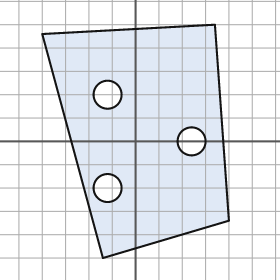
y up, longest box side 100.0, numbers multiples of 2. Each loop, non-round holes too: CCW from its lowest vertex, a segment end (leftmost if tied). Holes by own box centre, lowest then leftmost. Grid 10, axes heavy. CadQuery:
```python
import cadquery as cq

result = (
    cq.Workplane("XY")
    .moveTo(-14.0, -50.0)
    .lineTo(40.0, -34.0)
    .lineTo(34.0, 50.0)
    .lineTo(-40.0, 46.0)
    .close()
    .moveTo(-12.0, -20.0)
    .circle(6.0)
    .moveTo(24.0, 0.0)
    .circle(6.0)
    .moveTo(-12.0, 20.0)
    .circle(6.0)
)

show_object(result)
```